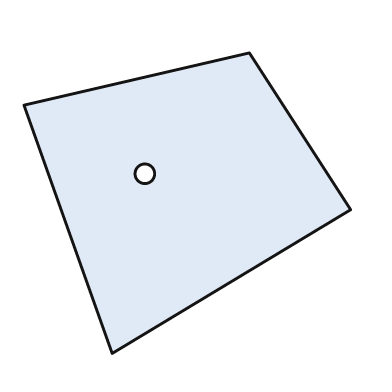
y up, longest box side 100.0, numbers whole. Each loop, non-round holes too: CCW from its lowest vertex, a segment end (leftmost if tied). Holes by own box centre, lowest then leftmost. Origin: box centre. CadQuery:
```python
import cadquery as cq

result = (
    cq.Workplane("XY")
    .moveTo(-23.0, -46.0)
    .lineTo(50.0, -2.0)
    .lineTo(19.0, 46.0)
    .lineTo(-50.0, 30.0)
    .close()
    .moveTo(-13.0, 9.0)
    .circle(3.0)
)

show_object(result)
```